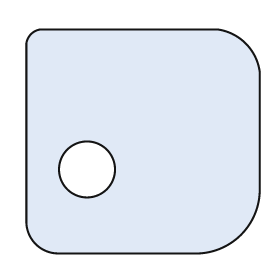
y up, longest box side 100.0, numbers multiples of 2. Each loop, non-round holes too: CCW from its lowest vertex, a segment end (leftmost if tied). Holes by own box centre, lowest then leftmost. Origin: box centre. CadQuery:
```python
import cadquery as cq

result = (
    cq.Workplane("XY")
    .moveTo(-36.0, -48.0)
    .lineTo(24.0, -48.0)
    .threePointArc((42.0, -40.0), (50.0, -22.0))
    .lineTo(50.0, 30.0)
    .threePointArc((44.0, 42.0), (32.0, 48.0))
    .lineTo(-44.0, 48.0)
    .threePointArc((-48.0, 46.0), (-50.0, 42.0))
    .lineTo(-50.0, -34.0)
    .threePointArc((-46.0, -44.0), (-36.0, -48.0))
    .close()
    .moveTo(-24.0, -12.0)
    .circle(12.0)
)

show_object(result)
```